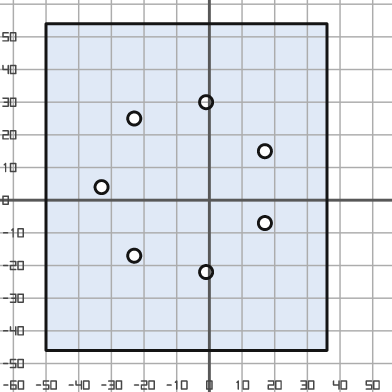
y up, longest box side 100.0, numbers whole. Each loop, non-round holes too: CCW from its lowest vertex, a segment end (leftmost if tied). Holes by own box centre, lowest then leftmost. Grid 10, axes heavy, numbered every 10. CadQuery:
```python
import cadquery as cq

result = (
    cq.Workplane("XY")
    .moveTo(-50.0, -46.0)
    .lineTo(36.0, -46.0)
    .lineTo(36.0, 54.0)
    .lineTo(-50.0, 54.0)
    .close()
    .moveTo(-1.0, -22.0)
    .circle(2.0)
    .moveTo(-23.0, -17.0)
    .circle(2.0)
    .moveTo(17.0, -7.0)
    .circle(2.0)
    .moveTo(-33.0, 4.0)
    .circle(2.0)
    .moveTo(17.0, 15.0)
    .circle(2.0)
    .moveTo(-23.0, 25.0)
    .circle(2.0)
    .moveTo(-1.0, 30.0)
    .circle(2.0)
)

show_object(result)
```